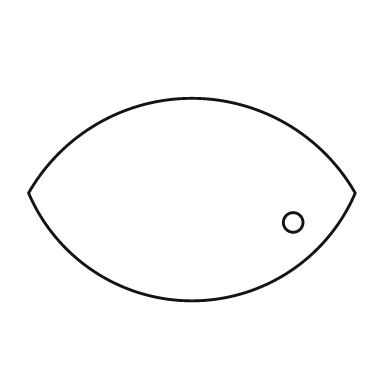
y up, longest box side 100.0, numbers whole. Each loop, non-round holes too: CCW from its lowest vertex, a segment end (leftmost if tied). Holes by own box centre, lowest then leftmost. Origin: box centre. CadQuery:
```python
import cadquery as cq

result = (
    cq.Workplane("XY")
    .moveTo(-50.0, 2.0)
    .threePointArc((0.0, -31.0), (50.0, 2.0))
    .threePointArc((0.0, 31.0), (-50.0, 2.0))
    .close()
    .moveTo(31.0, -7.0)
    .circle(3.0)
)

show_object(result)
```